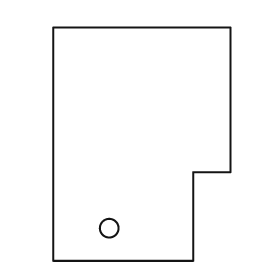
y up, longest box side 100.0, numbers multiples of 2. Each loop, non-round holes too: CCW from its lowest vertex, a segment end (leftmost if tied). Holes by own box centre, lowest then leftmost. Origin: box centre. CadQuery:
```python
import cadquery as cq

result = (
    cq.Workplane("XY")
    .moveTo(-38.0, -50.0)
    .lineTo(22.0, -50.0)
    .lineTo(22.0, -12.0)
    .lineTo(38.0, -12.0)
    .lineTo(38.0, 50.0)
    .lineTo(-38.0, 50.0)
    .close()
    .moveTo(-14.0, -36.0)
    .circle(4.0)
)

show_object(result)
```